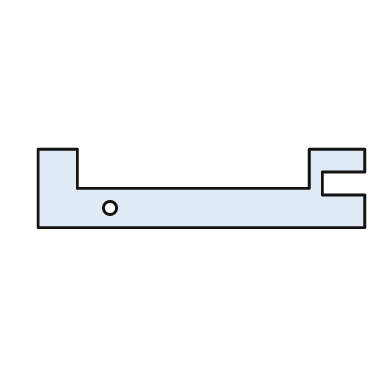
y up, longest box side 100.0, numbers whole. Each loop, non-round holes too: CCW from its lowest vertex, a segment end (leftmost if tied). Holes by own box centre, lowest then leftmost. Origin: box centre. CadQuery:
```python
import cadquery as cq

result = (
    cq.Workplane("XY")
    .moveTo(-50.0, -12.0)
    .lineTo(50.0, -12.0)
    .lineTo(50.0, -2.0)
    .lineTo(37.0, -2.0)
    .lineTo(37.0, 5.0)
    .lineTo(50.0, 5.0)
    .lineTo(50.0, 12.0)
    .lineTo(33.0, 12.0)
    .lineTo(33.0, 0.0)
    .lineTo(-38.0, 0.0)
    .lineTo(-38.0, 12.0)
    .lineTo(-50.0, 12.0)
    .close()
    .moveTo(-28.0, -6.0)
    .circle(2.0)
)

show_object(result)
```